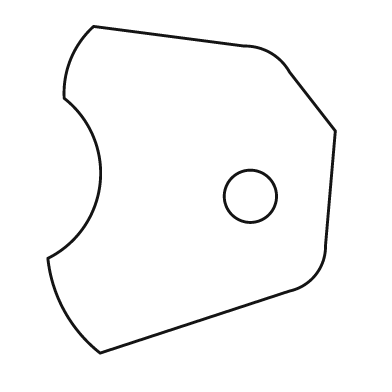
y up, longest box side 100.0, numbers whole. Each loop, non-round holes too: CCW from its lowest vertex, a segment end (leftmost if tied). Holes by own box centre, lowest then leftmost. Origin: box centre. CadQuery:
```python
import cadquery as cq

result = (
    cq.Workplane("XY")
    .moveTo(-28.0, -50.0)
    .lineTo(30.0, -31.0)
    .threePointArc((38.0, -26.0), (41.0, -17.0))
    .lineTo(44.0, 18.0)
    .lineTo(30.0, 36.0)
    .threePointArc((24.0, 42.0), (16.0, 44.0))
    .lineTo(-30.0, 50.0)
    .threePointArc((-37.0, 40.0), (-39.0, 28.0))
    .threePointArc((-28.0, 2.0), (-44.0, -21.0))
    .threePointArc((-39.0, -37.0), (-28.0, -50.0))
    .close()
    .moveTo(18.0, -2.0)
    .circle(8.0)
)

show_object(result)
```